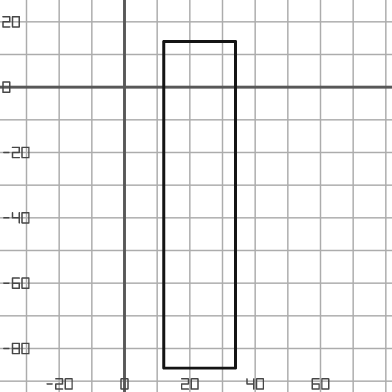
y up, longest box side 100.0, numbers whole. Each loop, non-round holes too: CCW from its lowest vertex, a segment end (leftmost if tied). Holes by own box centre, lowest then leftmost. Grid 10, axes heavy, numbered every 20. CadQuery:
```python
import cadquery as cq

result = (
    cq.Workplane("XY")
    .moveTo(12.0, -86.0)
    .lineTo(34.0, -86.0)
    .lineTo(34.0, 14.0)
    .lineTo(12.0, 14.0)
    .close()
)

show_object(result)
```